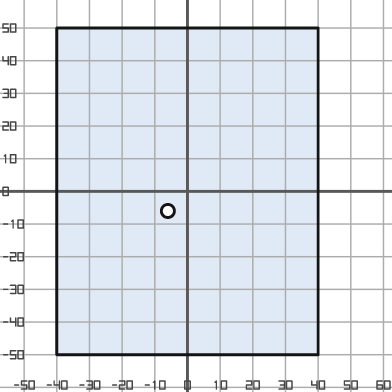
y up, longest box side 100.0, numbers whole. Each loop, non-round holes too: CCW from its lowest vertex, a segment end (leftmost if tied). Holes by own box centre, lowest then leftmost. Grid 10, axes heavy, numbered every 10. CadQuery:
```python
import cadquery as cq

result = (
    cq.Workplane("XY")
    .moveTo(-40.0, -50.0)
    .lineTo(40.0, -50.0)
    .lineTo(40.0, 50.0)
    .lineTo(-40.0, 50.0)
    .close()
    .moveTo(-6.0, -6.0)
    .circle(2.0)
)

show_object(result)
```